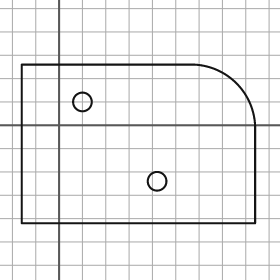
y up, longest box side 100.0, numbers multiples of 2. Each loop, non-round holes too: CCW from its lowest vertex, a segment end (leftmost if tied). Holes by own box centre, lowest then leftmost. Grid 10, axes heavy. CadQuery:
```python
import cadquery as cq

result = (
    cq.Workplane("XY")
    .moveTo(-16.0, -42.0)
    .lineTo(84.0, -42.0)
    .lineTo(84.0, 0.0)
    .threePointArc((76.0, 18.0), (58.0, 26.0))
    .lineTo(-16.0, 26.0)
    .close()
    .moveTo(42.0, -24.0)
    .circle(4.0)
    .moveTo(10.0, 10.0)
    .circle(4.0)
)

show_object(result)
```